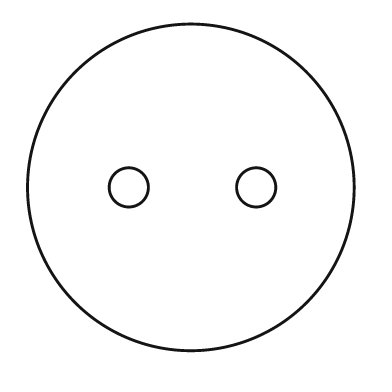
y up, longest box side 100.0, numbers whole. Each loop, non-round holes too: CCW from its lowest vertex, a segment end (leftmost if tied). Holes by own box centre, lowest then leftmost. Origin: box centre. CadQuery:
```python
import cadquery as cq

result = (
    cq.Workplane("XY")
    .moveTo(0.0, 0.0)
    .circle(50.0)
    .moveTo(-19.0, 0.0)
    .circle(6.0)
    .moveTo(20.0, 0.0)
    .circle(6.0)
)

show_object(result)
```